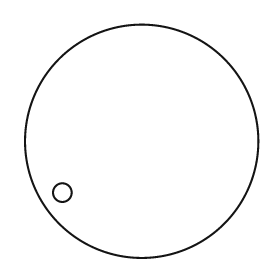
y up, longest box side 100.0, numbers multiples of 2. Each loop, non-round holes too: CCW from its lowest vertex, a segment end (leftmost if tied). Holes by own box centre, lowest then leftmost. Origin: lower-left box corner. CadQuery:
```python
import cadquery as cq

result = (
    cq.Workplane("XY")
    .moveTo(50.0, 50.0)
    .circle(50.0)
    .moveTo(16.0, 28.0)
    .circle(4.0)
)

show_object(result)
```